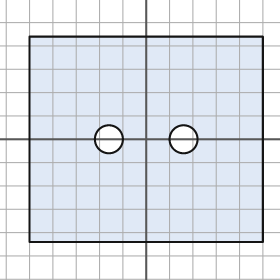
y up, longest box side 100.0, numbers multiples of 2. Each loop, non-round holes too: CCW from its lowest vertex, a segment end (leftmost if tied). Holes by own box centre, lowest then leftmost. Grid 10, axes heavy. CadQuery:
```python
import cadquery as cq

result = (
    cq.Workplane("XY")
    .moveTo(-50.0, -44.0)
    .lineTo(50.0, -44.0)
    .lineTo(50.0, 44.0)
    .lineTo(-50.0, 44.0)
    .close()
    .moveTo(-16.0, 0.0)
    .circle(6.0)
    .moveTo(16.0, 0.0)
    .circle(6.0)
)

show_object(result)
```